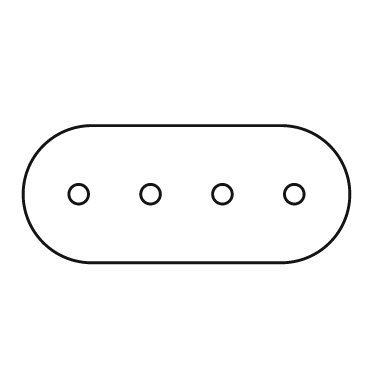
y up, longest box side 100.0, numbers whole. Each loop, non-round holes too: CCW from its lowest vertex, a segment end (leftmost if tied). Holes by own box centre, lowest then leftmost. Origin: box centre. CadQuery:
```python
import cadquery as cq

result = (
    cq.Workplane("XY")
    .moveTo(-29.0, -21.0)
    .lineTo(29.0, -21.0)
    .threePointArc((50.0, 0.0), (29.0, 21.0))
    .lineTo(-29.0, 21.0)
    .threePointArc((-50.0, 0.0), (-29.0, -21.0))
    .close()
    .moveTo(-33.0, 0.0)
    .circle(3.0)
    .moveTo(-11.0, 0.0)
    .circle(3.0)
    .moveTo(11.0, 0.0)
    .circle(3.0)
    .moveTo(33.0, 0.0)
    .circle(3.0)
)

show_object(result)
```